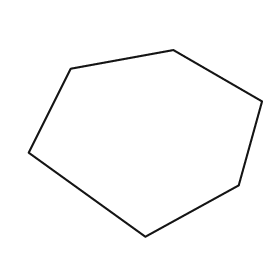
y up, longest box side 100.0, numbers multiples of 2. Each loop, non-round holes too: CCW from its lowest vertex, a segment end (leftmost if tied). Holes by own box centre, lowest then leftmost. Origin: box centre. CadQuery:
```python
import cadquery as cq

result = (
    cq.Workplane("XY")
    .moveTo(0.0, -40.0)
    .lineTo(40.0, -18.0)
    .lineTo(50.0, 18.0)
    .lineTo(12.0, 40.0)
    .lineTo(-32.0, 32.0)
    .lineTo(-50.0, -4.0)
    .close()
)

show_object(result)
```